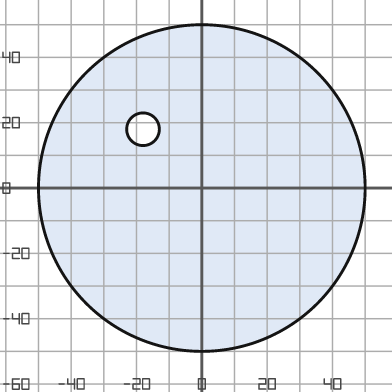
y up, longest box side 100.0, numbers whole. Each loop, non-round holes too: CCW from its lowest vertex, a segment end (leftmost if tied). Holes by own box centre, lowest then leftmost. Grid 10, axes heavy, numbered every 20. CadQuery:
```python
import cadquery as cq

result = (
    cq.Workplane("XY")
    .moveTo(0.0, 0.0)
    .circle(50.0)
    .moveTo(-18.0, 18.0)
    .circle(5.0)
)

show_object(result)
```